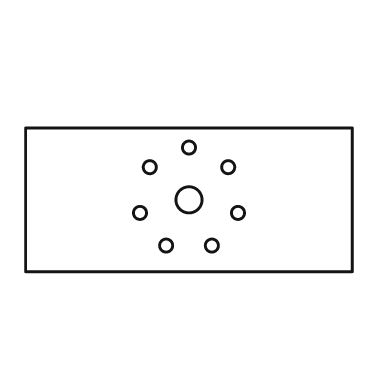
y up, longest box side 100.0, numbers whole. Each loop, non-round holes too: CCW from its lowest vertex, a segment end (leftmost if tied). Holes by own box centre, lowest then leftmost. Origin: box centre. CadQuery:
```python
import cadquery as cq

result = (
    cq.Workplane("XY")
    .moveTo(-50.0, -22.0)
    .lineTo(50.0, -22.0)
    .lineTo(50.0, 22.0)
    .lineTo(-50.0, 22.0)
    .close()
    .moveTo(-7.0, -14.0)
    .circle(2.0)
    .moveTo(7.0, -14.0)
    .circle(2.0)
    .moveTo(-15.0, -4.0)
    .circle(2.0)
    .moveTo(15.0, -4.0)
    .circle(2.0)
    .moveTo(0.0, 0.0)
    .circle(4.0)
    .moveTo(-12.0, 10.0)
    .circle(2.0)
    .moveTo(12.0, 10.0)
    .circle(2.0)
    .moveTo(0.0, 16.0)
    .circle(2.0)
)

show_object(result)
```